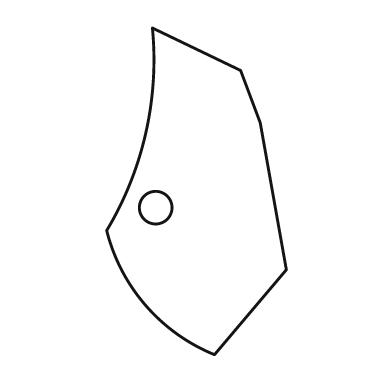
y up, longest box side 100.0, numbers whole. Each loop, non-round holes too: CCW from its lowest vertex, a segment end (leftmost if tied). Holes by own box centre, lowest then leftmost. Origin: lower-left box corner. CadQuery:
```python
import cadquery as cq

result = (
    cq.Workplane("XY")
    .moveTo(33.0, 0.0)
    .lineTo(55.0, 26.0)
    .lineTo(47.0, 71.0)
    .lineTo(41.0, 87.0)
    .lineTo(14.0, 100.0)
    .threePointArc((12.0, 68.0), (0.0, 38.0))
    .threePointArc((12.0, 15.0), (33.0, 0.0))
    .close()
    .moveTo(15.0, 45.0)
    .circle(5.0)
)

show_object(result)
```